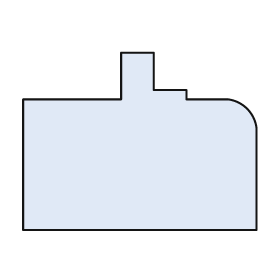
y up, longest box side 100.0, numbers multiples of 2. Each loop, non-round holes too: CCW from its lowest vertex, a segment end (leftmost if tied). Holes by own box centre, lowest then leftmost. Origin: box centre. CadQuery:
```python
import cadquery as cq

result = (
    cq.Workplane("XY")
    .moveTo(-50.0, -38.0)
    .lineTo(50.0, -38.0)
    .lineTo(50.0, 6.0)
    .threePointArc((46.0, 14.0), (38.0, 18.0))
    .lineTo(20.0, 18.0)
    .lineTo(20.0, 22.0)
    .lineTo(6.0, 22.0)
    .lineTo(6.0, 38.0)
    .lineTo(-8.0, 38.0)
    .lineTo(-8.0, 18.0)
    .lineTo(-50.0, 18.0)
    .close()
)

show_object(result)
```